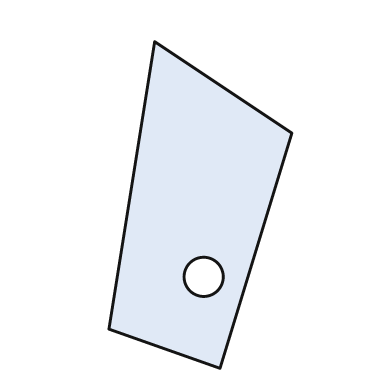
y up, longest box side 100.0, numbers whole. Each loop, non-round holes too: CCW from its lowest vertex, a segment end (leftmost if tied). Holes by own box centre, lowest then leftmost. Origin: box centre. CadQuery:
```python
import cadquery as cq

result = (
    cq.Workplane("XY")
    .moveTo(6.0, -50.0)
    .lineTo(28.0, 22.0)
    .lineTo(-14.0, 50.0)
    .lineTo(-28.0, -38.0)
    .close()
    .moveTo(1.0, -22.0)
    .circle(6.0)
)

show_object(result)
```